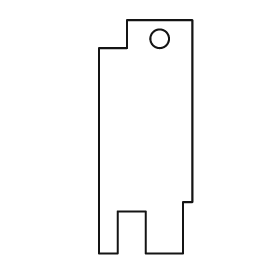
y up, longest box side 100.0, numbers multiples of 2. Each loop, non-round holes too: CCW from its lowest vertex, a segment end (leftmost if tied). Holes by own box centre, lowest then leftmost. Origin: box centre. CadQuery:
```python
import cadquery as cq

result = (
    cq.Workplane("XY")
    .moveTo(-20.0, -50.0)
    .lineTo(-12.0, -50.0)
    .lineTo(-12.0, -32.0)
    .lineTo(0.0, -32.0)
    .lineTo(0.0, -50.0)
    .lineTo(16.0, -50.0)
    .lineTo(16.0, -28.0)
    .lineTo(20.0, -28.0)
    .lineTo(20.0, 50.0)
    .lineTo(-8.0, 50.0)
    .lineTo(-8.0, 38.0)
    .lineTo(-20.0, 38.0)
    .close()
    .moveTo(6.0, 42.0)
    .circle(4.0)
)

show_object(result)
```